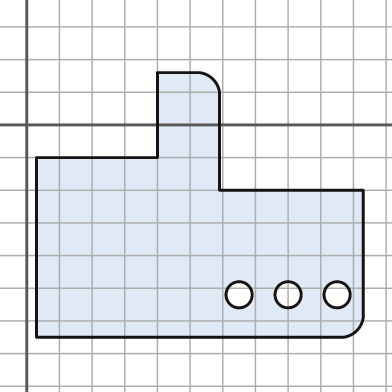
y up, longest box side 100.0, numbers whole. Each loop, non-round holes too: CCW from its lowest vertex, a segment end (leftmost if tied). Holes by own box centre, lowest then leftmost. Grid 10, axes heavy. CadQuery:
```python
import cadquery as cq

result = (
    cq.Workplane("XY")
    .moveTo(3.0, -65.0)
    .lineTo(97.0, -65.0)
    .threePointArc((101.0, -63.0), (103.0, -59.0))
    .lineTo(103.0, -20.0)
    .lineTo(59.0, -20.0)
    .lineTo(59.0, 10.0)
    .threePointArc((57.0, 14.0), (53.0, 16.0))
    .lineTo(40.0, 16.0)
    .lineTo(40.0, -10.0)
    .lineTo(3.0, -10.0)
    .close()
    .moveTo(65.0, -52.0)
    .circle(4.0)
    .moveTo(80.0, -52.0)
    .circle(4.0)
    .moveTo(95.0, -52.0)
    .circle(4.0)
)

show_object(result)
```